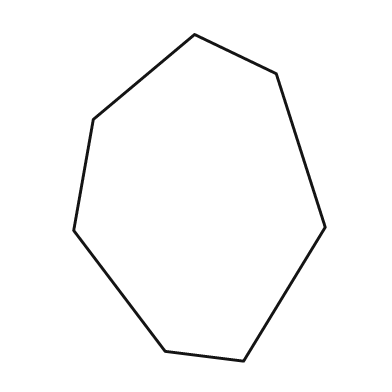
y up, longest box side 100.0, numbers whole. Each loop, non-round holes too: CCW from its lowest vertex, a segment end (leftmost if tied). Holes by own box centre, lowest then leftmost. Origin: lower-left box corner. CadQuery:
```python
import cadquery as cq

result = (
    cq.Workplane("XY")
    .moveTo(52.0, 0.0)
    .lineTo(77.0, 41.0)
    .lineTo(62.0, 88.0)
    .lineTo(37.0, 100.0)
    .lineTo(6.0, 74.0)
    .lineTo(0.0, 40.0)
    .lineTo(28.0, 3.0)
    .close()
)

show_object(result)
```